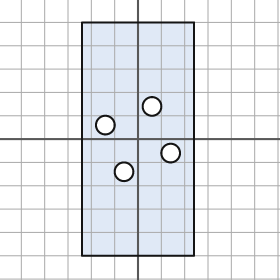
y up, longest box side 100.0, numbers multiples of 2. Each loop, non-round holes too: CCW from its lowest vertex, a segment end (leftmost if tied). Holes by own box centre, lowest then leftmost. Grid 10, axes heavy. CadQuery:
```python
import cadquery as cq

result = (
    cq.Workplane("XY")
    .moveTo(-24.0, -50.0)
    .lineTo(24.0, -50.0)
    .lineTo(24.0, 50.0)
    .lineTo(-24.0, 50.0)
    .close()
    .moveTo(-6.0, -14.0)
    .circle(4.0)
    .moveTo(14.0, -6.0)
    .circle(4.0)
    .moveTo(-14.0, 6.0)
    .circle(4.0)
    .moveTo(6.0, 14.0)
    .circle(4.0)
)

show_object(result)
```